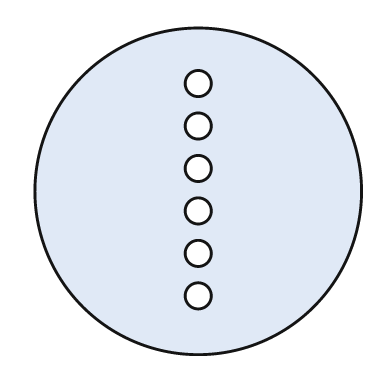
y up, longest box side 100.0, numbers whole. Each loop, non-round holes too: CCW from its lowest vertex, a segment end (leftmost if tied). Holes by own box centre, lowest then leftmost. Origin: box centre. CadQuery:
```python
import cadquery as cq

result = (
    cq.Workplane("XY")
    .moveTo(0.0, 0.0)
    .circle(50.0)
    .moveTo(0.0, -32.0)
    .circle(4.0)
    .moveTo(0.0, -19.0)
    .circle(4.0)
    .moveTo(0.0, -6.0)
    .circle(4.0)
    .moveTo(0.0, 7.0)
    .circle(4.0)
    .moveTo(0.0, 20.0)
    .circle(4.0)
    .moveTo(0.0, 33.0)
    .circle(4.0)
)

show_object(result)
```